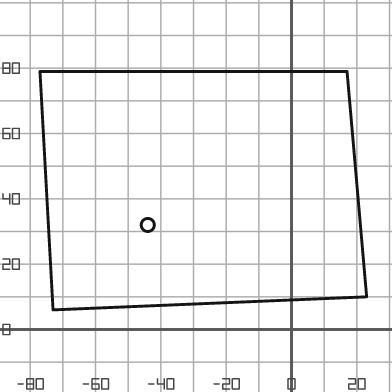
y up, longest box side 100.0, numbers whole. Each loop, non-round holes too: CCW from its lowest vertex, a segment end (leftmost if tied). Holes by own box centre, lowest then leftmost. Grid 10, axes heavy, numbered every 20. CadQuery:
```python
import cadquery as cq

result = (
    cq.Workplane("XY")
    .moveTo(-73.0, 6.0)
    .lineTo(23.0, 10.0)
    .lineTo(17.0, 79.0)
    .lineTo(-77.0, 79.0)
    .close()
    .moveTo(-44.0, 32.0)
    .circle(2.0)
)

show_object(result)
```